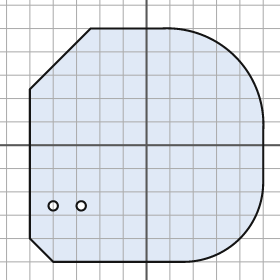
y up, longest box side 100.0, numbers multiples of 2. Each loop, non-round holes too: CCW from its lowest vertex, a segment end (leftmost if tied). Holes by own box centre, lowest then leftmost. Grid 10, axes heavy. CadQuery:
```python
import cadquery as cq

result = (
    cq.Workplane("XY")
    .moveTo(-40.0, -50.0)
    .lineTo(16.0, -50.0)
    .threePointArc((40.0, -40.0), (50.0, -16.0))
    .lineTo(50.0, 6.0)
    .threePointArc((38.0, 38.0), (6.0, 50.0))
    .lineTo(-24.0, 50.0)
    .lineTo(-50.0, 24.0)
    .lineTo(-50.0, -40.0)
    .close()
    .moveTo(-40.0, -26.0)
    .circle(2.0)
    .moveTo(-28.0, -26.0)
    .circle(2.0)
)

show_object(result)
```